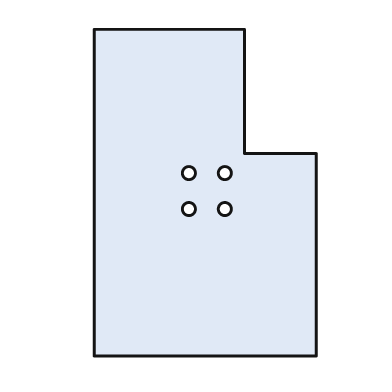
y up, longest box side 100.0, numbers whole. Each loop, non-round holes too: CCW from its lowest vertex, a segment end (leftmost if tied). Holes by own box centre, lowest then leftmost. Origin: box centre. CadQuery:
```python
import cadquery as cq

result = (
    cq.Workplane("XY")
    .moveTo(-34.0, -50.0)
    .lineTo(34.0, -50.0)
    .lineTo(34.0, 12.0)
    .lineTo(12.0, 12.0)
    .lineTo(12.0, 50.0)
    .lineTo(-34.0, 50.0)
    .close()
    .moveTo(-5.0, -5.0)
    .circle(2.0)
    .moveTo(6.0, -5.0)
    .circle(2.0)
    .moveTo(-5.0, 6.0)
    .circle(2.0)
    .moveTo(6.0, 6.0)
    .circle(2.0)
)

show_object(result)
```